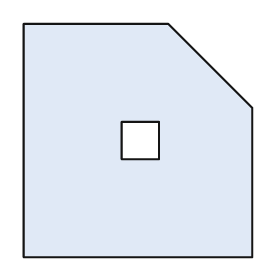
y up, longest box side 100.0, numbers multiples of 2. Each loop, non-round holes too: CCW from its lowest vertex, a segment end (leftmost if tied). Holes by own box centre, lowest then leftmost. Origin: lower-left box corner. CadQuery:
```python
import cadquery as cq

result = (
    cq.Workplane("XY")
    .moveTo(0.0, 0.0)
    .lineTo(98.0, 0.0)
    .lineTo(98.0, 64.0)
    .lineTo(62.0, 100.0)
    .lineTo(0.0, 100.0)
    .close()
    .moveTo(42.0, 42.0)
    .lineTo(58.0, 42.0)
    .lineTo(58.0, 58.0)
    .lineTo(42.0, 58.0)
    .close()
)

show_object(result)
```